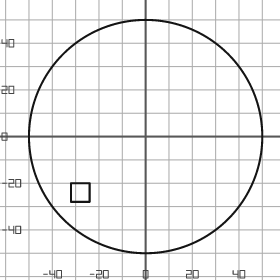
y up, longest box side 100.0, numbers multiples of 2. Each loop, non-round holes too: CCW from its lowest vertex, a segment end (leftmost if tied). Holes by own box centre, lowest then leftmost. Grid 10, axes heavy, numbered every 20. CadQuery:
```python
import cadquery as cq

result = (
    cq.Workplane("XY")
    .moveTo(0.0, 0.0)
    .circle(50.0)
    .moveTo(-32.0, -28.0)
    .lineTo(-24.0, -28.0)
    .lineTo(-24.0, -20.0)
    .lineTo(-32.0, -20.0)
    .close()
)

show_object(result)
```